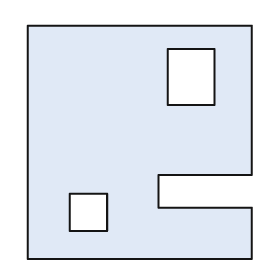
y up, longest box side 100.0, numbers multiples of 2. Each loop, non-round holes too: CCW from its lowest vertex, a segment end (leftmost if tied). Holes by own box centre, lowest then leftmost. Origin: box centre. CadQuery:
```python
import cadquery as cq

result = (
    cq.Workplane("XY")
    .moveTo(-48.0, -50.0)
    .lineTo(48.0, -50.0)
    .lineTo(48.0, -28.0)
    .lineTo(8.0, -28.0)
    .lineTo(8.0, -14.0)
    .lineTo(48.0, -14.0)
    .lineTo(48.0, 50.0)
    .lineTo(-48.0, 50.0)
    .close()
    .moveTo(-30.0, -38.0)
    .lineTo(-14.0, -38.0)
    .lineTo(-14.0, -22.0)
    .lineTo(-30.0, -22.0)
    .close()
    .moveTo(12.0, 16.0)
    .lineTo(32.0, 16.0)
    .lineTo(32.0, 40.0)
    .lineTo(12.0, 40.0)
    .close()
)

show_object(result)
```